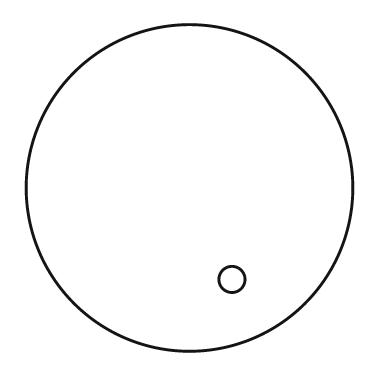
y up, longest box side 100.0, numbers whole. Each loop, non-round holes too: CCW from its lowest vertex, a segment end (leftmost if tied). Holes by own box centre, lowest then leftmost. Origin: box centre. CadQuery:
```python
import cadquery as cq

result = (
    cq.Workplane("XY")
    .moveTo(0.0, 0.0)
    .circle(50.0)
    .moveTo(13.0, -28.0)
    .circle(4.0)
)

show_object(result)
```